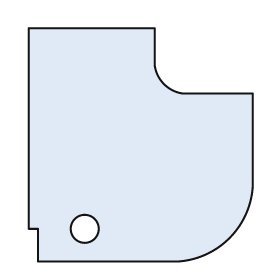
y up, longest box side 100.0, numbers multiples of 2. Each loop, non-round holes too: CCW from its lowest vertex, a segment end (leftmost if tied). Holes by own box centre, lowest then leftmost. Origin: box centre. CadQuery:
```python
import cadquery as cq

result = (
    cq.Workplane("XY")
    .moveTo(-44.0, -50.0)
    .lineTo(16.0, -50.0)
    .threePointArc((38.0, -40.0), (48.0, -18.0))
    .lineTo(48.0, 22.0)
    .lineTo(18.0, 22.0)
    .threePointArc((10.0, 26.0), (6.0, 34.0))
    .lineTo(6.0, 50.0)
    .lineTo(-48.0, 50.0)
    .lineTo(-48.0, -36.0)
    .lineTo(-44.0, -36.0)
    .close()
    .moveTo(-24.0, -36.0)
    .circle(6.0)
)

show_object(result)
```